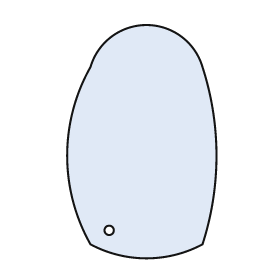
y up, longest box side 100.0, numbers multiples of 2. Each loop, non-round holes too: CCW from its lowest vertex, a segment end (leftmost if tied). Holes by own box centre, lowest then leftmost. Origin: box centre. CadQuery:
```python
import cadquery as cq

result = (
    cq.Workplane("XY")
    .moveTo(-22.0, -44.0)
    .threePointArc((2.0, -50.0), (26.0, -44.0))
    .threePointArc((32.0, -6.0), (26.0, 32.0))
    .threePointArc((2.0, 50.0), (-22.0, 32.0))
    .threePointArc((-32.0, -6.0), (-22.0, -44.0))
    .close()
    .moveTo(-14.0, -38.0)
    .circle(2.0)
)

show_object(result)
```